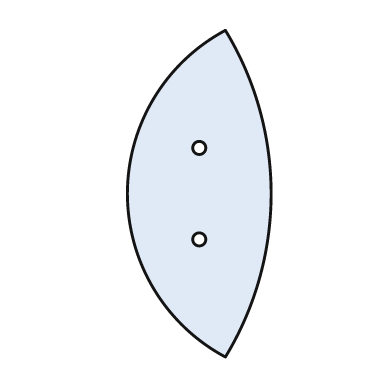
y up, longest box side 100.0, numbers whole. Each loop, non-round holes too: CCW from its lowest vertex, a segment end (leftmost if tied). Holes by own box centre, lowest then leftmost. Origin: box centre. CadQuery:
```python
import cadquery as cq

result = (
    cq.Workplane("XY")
    .moveTo(8.0, -50.0)
    .threePointArc((22.0, 0.0), (8.0, 50.0))
    .threePointArc((-22.0, 0.0), (8.0, -50.0))
    .close()
    .moveTo(0.0, -14.0)
    .circle(2.0)
    .moveTo(0.0, 14.0)
    .circle(2.0)
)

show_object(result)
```